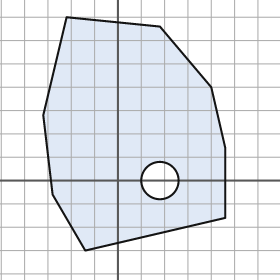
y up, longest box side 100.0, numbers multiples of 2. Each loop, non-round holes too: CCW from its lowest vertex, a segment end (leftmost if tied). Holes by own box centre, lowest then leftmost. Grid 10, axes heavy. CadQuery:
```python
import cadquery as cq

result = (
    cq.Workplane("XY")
    .moveTo(-14.0, -30.0)
    .lineTo(46.0, -16.0)
    .lineTo(46.0, 14.0)
    .lineTo(40.0, 40.0)
    .lineTo(18.0, 66.0)
    .lineTo(-22.0, 70.0)
    .lineTo(-32.0, 28.0)
    .lineTo(-28.0, -6.0)
    .close()
    .moveTo(18.0, 0.0)
    .circle(8.0)
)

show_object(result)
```